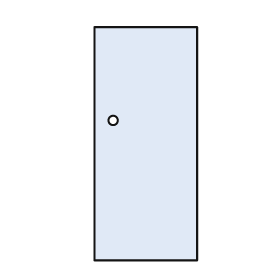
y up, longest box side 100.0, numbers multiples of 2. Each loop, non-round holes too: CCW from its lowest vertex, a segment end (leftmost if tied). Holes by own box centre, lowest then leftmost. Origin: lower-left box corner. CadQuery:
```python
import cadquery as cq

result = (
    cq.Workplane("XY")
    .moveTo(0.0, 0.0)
    .lineTo(44.0, 0.0)
    .lineTo(44.0, 100.0)
    .lineTo(0.0, 100.0)
    .close()
    .moveTo(8.0, 60.0)
    .circle(2.0)
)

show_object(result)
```